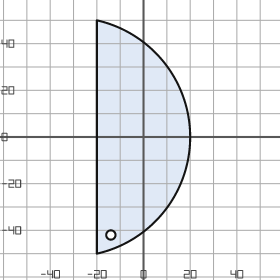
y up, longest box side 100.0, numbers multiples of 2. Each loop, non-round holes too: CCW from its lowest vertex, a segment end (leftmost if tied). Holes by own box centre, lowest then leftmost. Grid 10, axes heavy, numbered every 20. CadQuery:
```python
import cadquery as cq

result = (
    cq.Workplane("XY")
    .moveTo(-20.0, -50.0)
    .threePointArc((20.0, 0.0), (-20.0, 50.0))
    .close()
    .moveTo(-14.0, -42.0)
    .circle(2.0)
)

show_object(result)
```